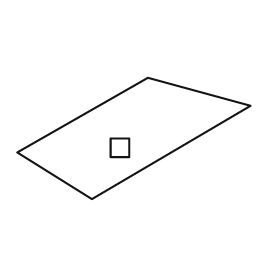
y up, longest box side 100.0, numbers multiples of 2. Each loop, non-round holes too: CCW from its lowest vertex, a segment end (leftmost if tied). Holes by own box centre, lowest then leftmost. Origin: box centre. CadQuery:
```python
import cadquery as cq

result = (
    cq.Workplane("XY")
    .moveTo(-18.0, -26.0)
    .lineTo(50.0, 14.0)
    .lineTo(6.0, 26.0)
    .lineTo(-50.0, -6.0)
    .close()
    .moveTo(-10.0, -8.0)
    .lineTo(-2.0, -8.0)
    .lineTo(-2.0, 0.0)
    .lineTo(-10.0, 0.0)
    .close()
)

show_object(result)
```